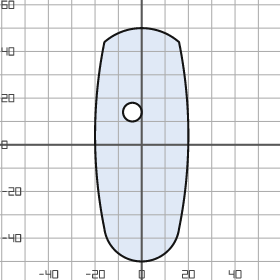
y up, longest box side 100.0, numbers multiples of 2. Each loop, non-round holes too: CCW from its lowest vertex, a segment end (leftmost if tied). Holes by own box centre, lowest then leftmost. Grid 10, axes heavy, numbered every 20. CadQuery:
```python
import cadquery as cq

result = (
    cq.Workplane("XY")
    .moveTo(-16.0, -36.0)
    .threePointArc((0.0, -50.0), (16.0, -36.0))
    .threePointArc((20.0, 4.0), (16.0, 44.0))
    .threePointArc((0.0, 50.0), (-16.0, 44.0))
    .threePointArc((-20.0, 4.0), (-16.0, -36.0))
    .close()
    .moveTo(-4.0, 14.0)
    .circle(4.0)
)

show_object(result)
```